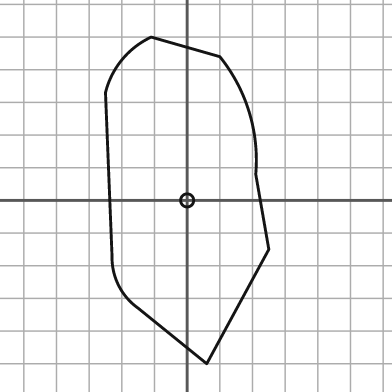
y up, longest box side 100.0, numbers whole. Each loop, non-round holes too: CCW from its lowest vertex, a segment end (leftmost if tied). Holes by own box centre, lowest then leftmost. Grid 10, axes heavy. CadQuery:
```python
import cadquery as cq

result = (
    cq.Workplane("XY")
    .moveTo(6.0, -50.0)
    .lineTo(25.0, -15.0)
    .lineTo(21.0, 8.0)
    .threePointArc((19.0, 27.0), (10.0, 44.0))
    .lineTo(-11.0, 50.0)
    .threePointArc((-20.0, 43.0), (-25.0, 33.0))
    .lineTo(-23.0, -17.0)
    .threePointArc((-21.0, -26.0), (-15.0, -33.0))
    .close()
    .moveTo(0.0, 0.0)
    .circle(2.0)
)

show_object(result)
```